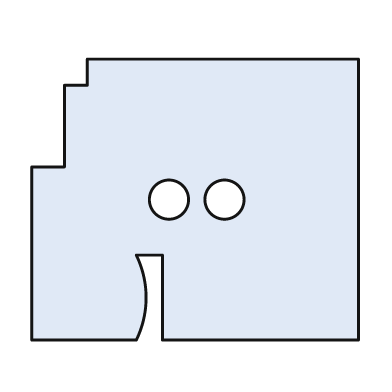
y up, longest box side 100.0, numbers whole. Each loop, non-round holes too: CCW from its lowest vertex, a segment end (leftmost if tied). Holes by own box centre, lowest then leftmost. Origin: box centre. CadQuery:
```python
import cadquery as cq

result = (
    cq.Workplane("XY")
    .moveTo(-50.0, -43.0)
    .lineTo(-18.0, -43.0)
    .threePointArc((-15.0, -30.0), (-18.0, -17.0))
    .lineTo(-10.0, -17.0)
    .lineTo(-10.0, -43.0)
    .lineTo(50.0, -43.0)
    .lineTo(50.0, 43.0)
    .lineTo(-33.0, 43.0)
    .lineTo(-33.0, 35.0)
    .lineTo(-40.0, 35.0)
    .lineTo(-40.0, 10.0)
    .lineTo(-50.0, 10.0)
    .close()
    .moveTo(-8.0, 0.0)
    .circle(6.0)
    .moveTo(9.0, 0.0)
    .circle(6.0)
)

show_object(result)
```